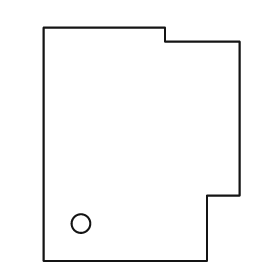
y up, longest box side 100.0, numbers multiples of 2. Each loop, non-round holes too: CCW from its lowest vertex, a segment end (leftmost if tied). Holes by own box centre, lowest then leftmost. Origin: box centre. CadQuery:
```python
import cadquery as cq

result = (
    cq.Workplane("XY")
    .moveTo(-42.0, -50.0)
    .lineTo(28.0, -50.0)
    .lineTo(28.0, -22.0)
    .lineTo(42.0, -22.0)
    .lineTo(42.0, 44.0)
    .lineTo(10.0, 44.0)
    .lineTo(10.0, 50.0)
    .lineTo(-42.0, 50.0)
    .close()
    .moveTo(-26.0, -34.0)
    .circle(4.0)
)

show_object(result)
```